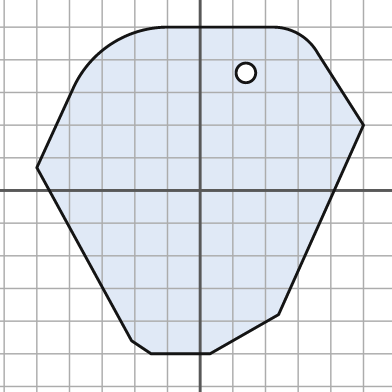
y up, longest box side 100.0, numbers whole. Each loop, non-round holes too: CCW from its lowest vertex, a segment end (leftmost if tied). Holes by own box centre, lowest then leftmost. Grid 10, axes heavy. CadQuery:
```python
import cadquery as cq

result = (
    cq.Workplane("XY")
    .moveTo(-15.0, -50.0)
    .lineTo(3.0, -50.0)
    .lineTo(24.0, -38.0)
    .lineTo(50.0, 20.0)
    .lineTo(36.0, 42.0)
    .threePointArc((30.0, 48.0), (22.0, 50.0))
    .lineTo(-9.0, 50.0)
    .threePointArc((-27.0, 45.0), (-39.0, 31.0))
    .lineTo(-50.0, 7.0)
    .lineTo(-21.0, -46.0)
    .close()
    .moveTo(14.0, 36.0)
    .circle(3.0)
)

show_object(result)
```